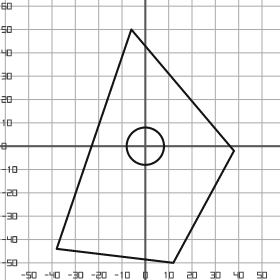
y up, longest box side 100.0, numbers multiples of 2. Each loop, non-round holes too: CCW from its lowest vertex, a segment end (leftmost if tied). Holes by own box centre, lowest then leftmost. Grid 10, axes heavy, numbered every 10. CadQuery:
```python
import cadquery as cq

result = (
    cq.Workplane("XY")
    .moveTo(12.0, -50.0)
    .lineTo(38.0, -2.0)
    .lineTo(-6.0, 50.0)
    .lineTo(-38.0, -44.0)
    .close()
    .moveTo(0.0, 0.0)
    .circle(8.0)
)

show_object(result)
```